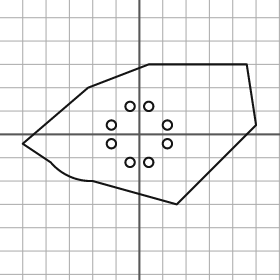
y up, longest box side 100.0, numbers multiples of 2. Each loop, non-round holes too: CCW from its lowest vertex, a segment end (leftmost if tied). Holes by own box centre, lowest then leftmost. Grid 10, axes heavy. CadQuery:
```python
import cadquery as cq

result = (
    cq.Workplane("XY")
    .moveTo(16.0, -30.0)
    .lineTo(50.0, 4.0)
    .lineTo(46.0, 30.0)
    .lineTo(4.0, 30.0)
    .lineTo(-22.0, 20.0)
    .lineTo(-50.0, -4.0)
    .lineTo(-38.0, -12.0)
    .threePointArc((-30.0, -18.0), (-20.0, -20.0))
    .close()
    .moveTo(-4.0, -12.0)
    .circle(2.0)
    .moveTo(4.0, -12.0)
    .circle(2.0)
    .moveTo(-12.0, -4.0)
    .circle(2.0)
    .moveTo(12.0, -4.0)
    .circle(2.0)
    .moveTo(-12.0, 4.0)
    .circle(2.0)
    .moveTo(12.0, 4.0)
    .circle(2.0)
    .moveTo(-4.0, 12.0)
    .circle(2.0)
    .moveTo(4.0, 12.0)
    .circle(2.0)
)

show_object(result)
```